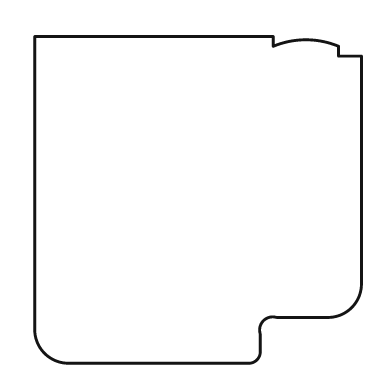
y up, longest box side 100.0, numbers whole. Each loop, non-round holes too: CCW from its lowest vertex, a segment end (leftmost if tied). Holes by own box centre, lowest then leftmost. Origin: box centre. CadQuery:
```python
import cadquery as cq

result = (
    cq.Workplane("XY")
    .moveTo(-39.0, -50.0)
    .lineTo(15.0, -50.0)
    .threePointArc((18.0, -49.0), (19.0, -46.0))
    .lineTo(19.0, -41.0)
    .threePointArc((20.0, -37.0), (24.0, -36.0))
    .lineTo(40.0, -36.0)
    .threePointArc((47.0, -33.0), (50.0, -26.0))
    .lineTo(50.0, 44.0)
    .lineTo(43.0, 44.0)
    .lineTo(43.0, 47.0)
    .threePointArc((33.0, 49.0), (23.0, 47.0))
    .lineTo(23.0, 50.0)
    .lineTo(-50.0, 50.0)
    .lineTo(-50.0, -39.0)
    .threePointArc((-47.0, -47.0), (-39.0, -50.0))
    .close()
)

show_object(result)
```